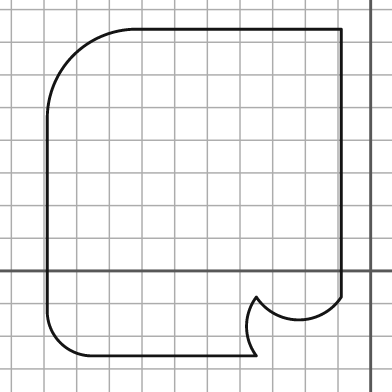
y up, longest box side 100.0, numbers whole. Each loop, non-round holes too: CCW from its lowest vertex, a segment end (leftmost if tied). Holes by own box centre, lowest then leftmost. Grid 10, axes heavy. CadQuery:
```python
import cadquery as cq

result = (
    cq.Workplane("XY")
    .moveTo(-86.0, -26.0)
    .lineTo(-35.0, -26.0)
    .threePointArc((-38.0, -17.0), (-35.0, -8.0))
    .threePointArc((-22.0, -15.0), (-9.0, -8.0))
    .lineTo(-9.0, 74.0)
    .lineTo(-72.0, 74.0)
    .threePointArc((-91.0, 66.0), (-99.0, 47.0))
    .lineTo(-99.0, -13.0)
    .threePointArc((-95.0, -22.0), (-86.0, -26.0))
    .close()
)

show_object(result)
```